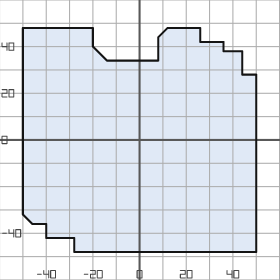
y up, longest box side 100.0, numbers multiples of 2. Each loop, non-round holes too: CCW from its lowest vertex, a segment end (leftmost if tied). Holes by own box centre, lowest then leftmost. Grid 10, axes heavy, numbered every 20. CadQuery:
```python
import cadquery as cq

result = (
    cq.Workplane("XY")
    .moveTo(-28.0, -48.0)
    .lineTo(50.0, -48.0)
    .lineTo(50.0, 28.0)
    .lineTo(44.0, 28.0)
    .lineTo(44.0, 38.0)
    .lineTo(36.0, 38.0)
    .lineTo(36.0, 42.0)
    .lineTo(26.0, 42.0)
    .lineTo(26.0, 48.0)
    .lineTo(12.0, 48.0)
    .lineTo(8.0, 44.0)
    .lineTo(8.0, 34.0)
    .lineTo(-14.0, 34.0)
    .lineTo(-20.0, 40.0)
    .lineTo(-20.0, 48.0)
    .lineTo(-50.0, 48.0)
    .lineTo(-50.0, -32.0)
    .lineTo(-46.0, -36.0)
    .lineTo(-40.0, -36.0)
    .lineTo(-40.0, -42.0)
    .lineTo(-28.0, -42.0)
    .close()
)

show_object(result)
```